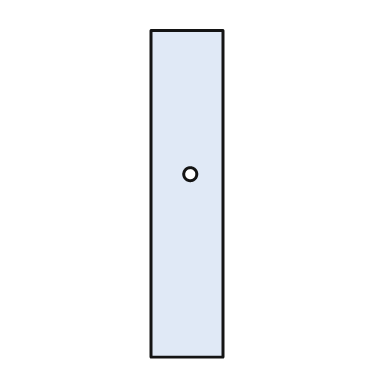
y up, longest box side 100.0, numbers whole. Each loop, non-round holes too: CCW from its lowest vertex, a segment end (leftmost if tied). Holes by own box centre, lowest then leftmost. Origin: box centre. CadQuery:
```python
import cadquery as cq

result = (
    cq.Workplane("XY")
    .moveTo(-11.0, -50.0)
    .lineTo(11.0, -50.0)
    .lineTo(11.0, 50.0)
    .lineTo(-11.0, 50.0)
    .close()
    .moveTo(1.0, 6.0)
    .circle(2.0)
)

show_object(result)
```